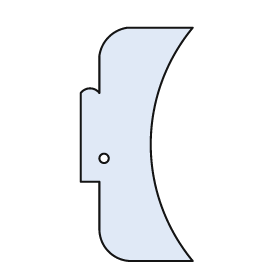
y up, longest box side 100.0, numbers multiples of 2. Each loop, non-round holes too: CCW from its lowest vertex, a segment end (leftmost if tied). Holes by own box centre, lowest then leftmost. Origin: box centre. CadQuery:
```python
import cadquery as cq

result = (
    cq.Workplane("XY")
    .moveTo(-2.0, -50.0)
    .lineTo(24.0, -50.0)
    .threePointArc((6.0, 0.0), (24.0, 50.0))
    .lineTo(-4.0, 50.0)
    .threePointArc((-12.0, 46.0), (-16.0, 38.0))
    .lineTo(-16.0, 22.0)
    .threePointArc((-20.0, 24.0), (-24.0, 22.0))
    .lineTo(-24.0, -16.0)
    .lineTo(-16.0, -16.0)
    .lineTo(-16.0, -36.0)
    .threePointArc((-12.0, -46.0), (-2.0, -50.0))
    .close()
    .moveTo(-14.0, -6.0)
    .circle(2.0)
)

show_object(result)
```